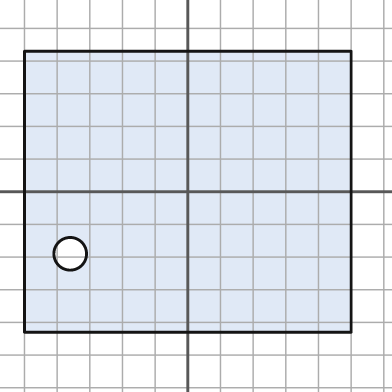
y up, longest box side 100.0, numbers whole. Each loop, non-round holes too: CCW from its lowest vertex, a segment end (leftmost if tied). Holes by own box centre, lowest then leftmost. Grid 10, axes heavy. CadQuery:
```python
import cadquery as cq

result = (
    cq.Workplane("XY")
    .moveTo(-50.0, -43.0)
    .lineTo(50.0, -43.0)
    .lineTo(50.0, 43.0)
    .lineTo(-50.0, 43.0)
    .close()
    .moveTo(-36.0, -19.0)
    .circle(5.0)
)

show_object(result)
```